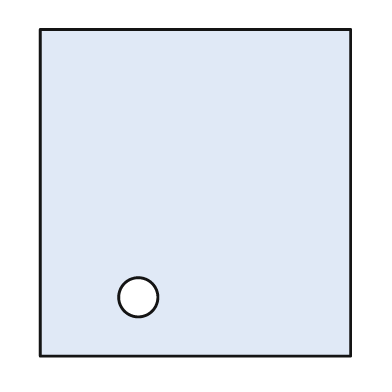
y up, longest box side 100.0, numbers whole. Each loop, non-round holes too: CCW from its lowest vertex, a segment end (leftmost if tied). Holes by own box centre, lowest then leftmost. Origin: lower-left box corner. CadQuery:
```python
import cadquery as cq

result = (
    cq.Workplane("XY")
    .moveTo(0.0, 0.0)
    .lineTo(95.0, 0.0)
    .lineTo(95.0, 100.0)
    .lineTo(0.0, 100.0)
    .close()
    .moveTo(30.0, 18.0)
    .circle(6.0)
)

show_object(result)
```